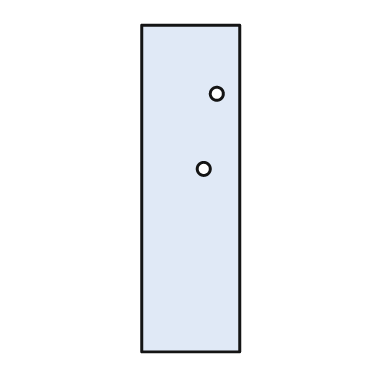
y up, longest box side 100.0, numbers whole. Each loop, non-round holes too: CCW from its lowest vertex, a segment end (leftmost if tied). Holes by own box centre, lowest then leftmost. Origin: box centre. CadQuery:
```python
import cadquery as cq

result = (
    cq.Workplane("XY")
    .moveTo(-15.0, -50.0)
    .lineTo(15.0, -50.0)
    .lineTo(15.0, 50.0)
    .lineTo(-15.0, 50.0)
    .close()
    .moveTo(4.0, 6.0)
    .circle(2.0)
    .moveTo(8.0, 29.0)
    .circle(2.0)
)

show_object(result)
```